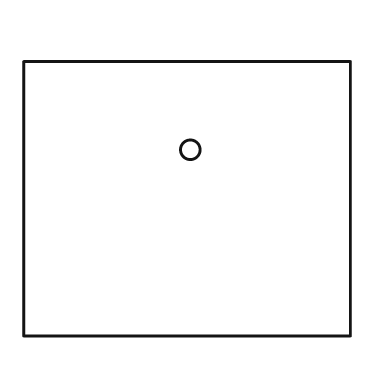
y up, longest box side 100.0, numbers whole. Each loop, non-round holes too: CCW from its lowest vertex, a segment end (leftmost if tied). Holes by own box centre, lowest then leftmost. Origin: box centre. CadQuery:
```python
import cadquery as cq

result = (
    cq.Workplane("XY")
    .moveTo(-50.0, -42.0)
    .lineTo(50.0, -42.0)
    .lineTo(50.0, 42.0)
    .lineTo(-50.0, 42.0)
    .close()
    .moveTo(1.0, 15.0)
    .circle(3.0)
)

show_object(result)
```